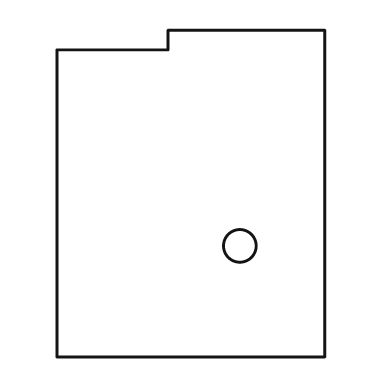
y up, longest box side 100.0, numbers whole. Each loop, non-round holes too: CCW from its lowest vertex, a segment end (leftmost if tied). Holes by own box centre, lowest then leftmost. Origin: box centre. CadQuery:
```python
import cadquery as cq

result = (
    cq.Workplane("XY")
    .moveTo(-41.0, -50.0)
    .lineTo(41.0, -50.0)
    .lineTo(41.0, 50.0)
    .lineTo(-7.0, 50.0)
    .lineTo(-7.0, 44.0)
    .lineTo(-41.0, 44.0)
    .close()
    .moveTo(15.0, -16.0)
    .circle(5.0)
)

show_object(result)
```